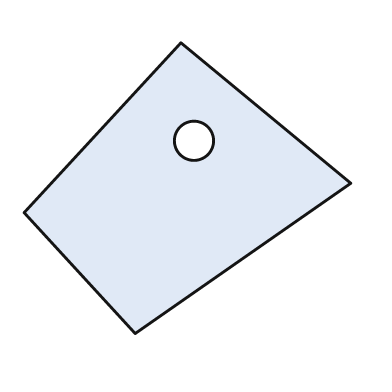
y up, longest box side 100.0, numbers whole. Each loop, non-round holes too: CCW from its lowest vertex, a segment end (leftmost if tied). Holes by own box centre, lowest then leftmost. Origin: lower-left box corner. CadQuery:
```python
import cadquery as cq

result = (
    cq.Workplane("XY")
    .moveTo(34.0, 0.0)
    .lineTo(100.0, 46.0)
    .lineTo(48.0, 89.0)
    .lineTo(0.0, 37.0)
    .close()
    .moveTo(52.0, 59.0)
    .circle(6.0)
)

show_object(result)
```